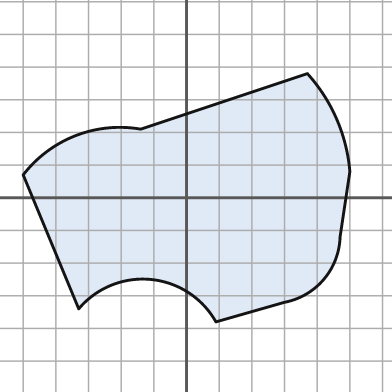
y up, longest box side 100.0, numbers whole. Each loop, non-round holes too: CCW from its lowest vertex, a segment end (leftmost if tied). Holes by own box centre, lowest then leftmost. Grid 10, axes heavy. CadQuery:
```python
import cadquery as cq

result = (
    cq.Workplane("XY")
    .moveTo(9.0, -38.0)
    .lineTo(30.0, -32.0)
    .threePointArc((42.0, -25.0), (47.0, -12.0))
    .lineTo(50.0, 8.0)
    .threePointArc((46.0, 24.0), (37.0, 38.0))
    .lineTo(-14.0, 21.0)
    .threePointArc((-34.0, 19.0), (-50.0, 7.0))
    .lineTo(-33.0, -34.0)
    .threePointArc((-11.0, -25.0), (9.0, -38.0))
    .close()
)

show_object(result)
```